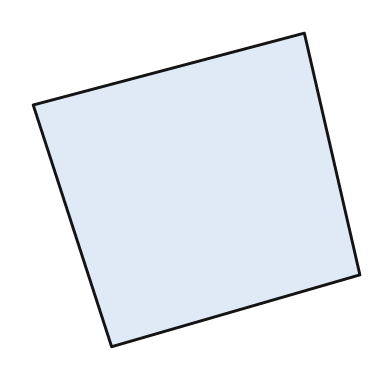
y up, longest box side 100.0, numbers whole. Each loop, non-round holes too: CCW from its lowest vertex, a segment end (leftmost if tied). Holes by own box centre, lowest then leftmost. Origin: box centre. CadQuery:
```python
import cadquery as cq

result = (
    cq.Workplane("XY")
    .moveTo(-26.0, -48.0)
    .lineTo(50.0, -26.0)
    .lineTo(33.0, 48.0)
    .lineTo(-50.0, 26.0)
    .close()
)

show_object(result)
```